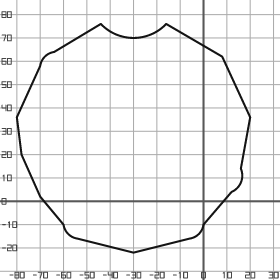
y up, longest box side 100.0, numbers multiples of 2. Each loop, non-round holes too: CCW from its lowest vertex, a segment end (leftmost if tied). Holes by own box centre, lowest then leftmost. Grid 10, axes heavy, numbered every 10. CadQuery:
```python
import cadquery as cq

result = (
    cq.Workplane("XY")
    .moveTo(-30.0, -22.0)
    .lineTo(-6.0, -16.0)
    .threePointArc((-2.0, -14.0), (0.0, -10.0))
    .lineTo(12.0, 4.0)
    .threePointArc((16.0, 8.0), (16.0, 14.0))
    .lineTo(20.0, 36.0)
    .lineTo(8.0, 62.0)
    .lineTo(-16.0, 76.0)
    .threePointArc((-30.0, 70.0), (-44.0, 76.0))
    .lineTo(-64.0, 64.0)
    .threePointArc((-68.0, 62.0), (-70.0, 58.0))
    .lineTo(-80.0, 36.0)
    .lineTo(-78.0, 20.0)
    .lineTo(-70.0, 2.0)
    .lineTo(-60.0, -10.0)
    .threePointArc((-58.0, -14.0), (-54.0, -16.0))
    .close()
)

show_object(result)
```